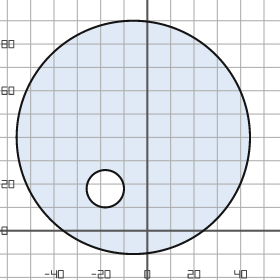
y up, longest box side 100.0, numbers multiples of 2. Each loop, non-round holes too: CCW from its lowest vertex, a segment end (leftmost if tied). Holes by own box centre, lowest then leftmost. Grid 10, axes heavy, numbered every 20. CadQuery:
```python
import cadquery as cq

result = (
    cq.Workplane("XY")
    .moveTo(-6.0, 40.0)
    .circle(50.0)
    .moveTo(-18.0, 18.0)
    .circle(8.0)
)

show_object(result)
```